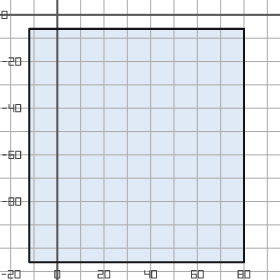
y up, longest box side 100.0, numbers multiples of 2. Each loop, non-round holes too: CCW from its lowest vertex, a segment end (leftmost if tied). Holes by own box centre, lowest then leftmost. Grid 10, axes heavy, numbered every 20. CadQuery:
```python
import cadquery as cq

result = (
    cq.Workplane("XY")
    .moveTo(-12.0, -106.0)
    .lineTo(80.0, -106.0)
    .lineTo(80.0, -6.0)
    .lineTo(-12.0, -6.0)
    .close()
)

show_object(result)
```